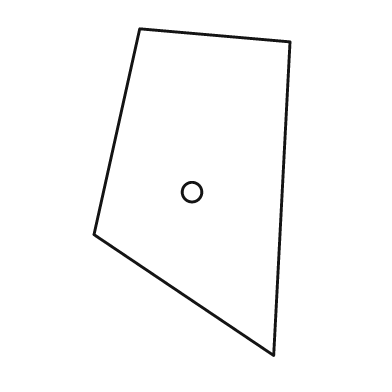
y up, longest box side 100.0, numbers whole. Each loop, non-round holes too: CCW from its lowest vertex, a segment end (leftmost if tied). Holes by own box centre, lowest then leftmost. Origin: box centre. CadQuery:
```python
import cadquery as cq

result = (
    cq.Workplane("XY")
    .moveTo(25.0, -50.0)
    .lineTo(30.0, 46.0)
    .lineTo(-16.0, 50.0)
    .lineTo(-30.0, -13.0)
    .close()
    .moveTo(0.0, 0.0)
    .circle(3.0)
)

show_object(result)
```